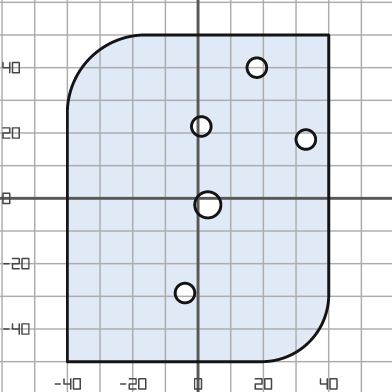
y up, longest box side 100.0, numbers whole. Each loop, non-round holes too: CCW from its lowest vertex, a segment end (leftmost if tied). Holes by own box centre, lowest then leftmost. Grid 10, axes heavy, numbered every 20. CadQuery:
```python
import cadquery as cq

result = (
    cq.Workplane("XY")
    .moveTo(-40.0, -50.0)
    .lineTo(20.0, -50.0)
    .threePointArc((34.0, -44.0), (40.0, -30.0))
    .lineTo(40.0, 50.0)
    .lineTo(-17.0, 50.0)
    .threePointArc((-33.0, 43.0), (-40.0, 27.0))
    .close()
    .moveTo(-4.0, -29.0)
    .circle(3.0)
    .moveTo(3.0, -2.0)
    .circle(4.0)
    .moveTo(33.0, 18.0)
    .circle(3.0)
    .moveTo(1.0, 22.0)
    .circle(3.0)
    .moveTo(18.0, 40.0)
    .circle(3.0)
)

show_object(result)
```